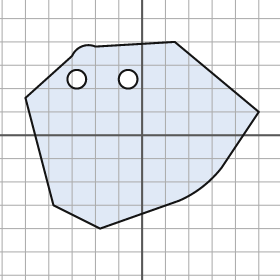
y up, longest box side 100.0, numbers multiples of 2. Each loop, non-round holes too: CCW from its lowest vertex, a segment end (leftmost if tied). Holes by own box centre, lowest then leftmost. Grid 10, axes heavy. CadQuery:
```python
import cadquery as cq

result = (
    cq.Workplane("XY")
    .moveTo(-18.0, -40.0)
    .lineTo(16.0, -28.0)
    .threePointArc((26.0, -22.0), (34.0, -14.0))
    .lineTo(50.0, 10.0)
    .lineTo(14.0, 40.0)
    .lineTo(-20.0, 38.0)
    .threePointArc((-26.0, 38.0), (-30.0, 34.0))
    .lineTo(-50.0, 16.0)
    .lineTo(-38.0, -30.0)
    .close()
    .moveTo(-28.0, 24.0)
    .circle(4.0)
    .moveTo(-6.0, 24.0)
    .circle(4.0)
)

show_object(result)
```